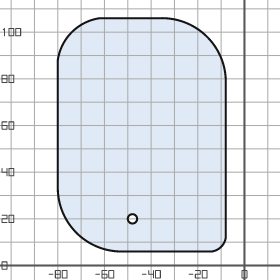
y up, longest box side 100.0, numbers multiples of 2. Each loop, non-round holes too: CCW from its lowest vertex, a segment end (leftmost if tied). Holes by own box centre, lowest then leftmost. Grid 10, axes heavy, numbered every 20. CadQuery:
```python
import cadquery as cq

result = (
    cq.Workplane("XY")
    .moveTo(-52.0, 6.0)
    .lineTo(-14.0, 6.0)
    .threePointArc((-10.0, 8.0), (-8.0, 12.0))
    .lineTo(-8.0, 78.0)
    .threePointArc((-16.0, 98.0), (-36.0, 106.0))
    .lineTo(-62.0, 106.0)
    .threePointArc((-74.0, 100.0), (-80.0, 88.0))
    .lineTo(-80.0, 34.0)
    .threePointArc((-72.0, 14.0), (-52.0, 6.0))
    .close()
    .moveTo(-48.0, 20.0)
    .circle(2.0)
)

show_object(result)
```